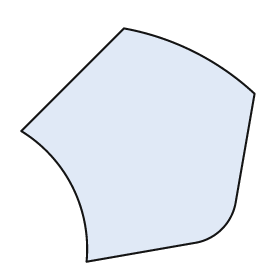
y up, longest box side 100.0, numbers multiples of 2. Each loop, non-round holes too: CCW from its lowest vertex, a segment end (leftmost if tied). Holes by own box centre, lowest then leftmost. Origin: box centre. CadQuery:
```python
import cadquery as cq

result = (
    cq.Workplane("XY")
    .moveTo(-22.0, -50.0)
    .lineTo(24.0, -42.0)
    .threePointArc((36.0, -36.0), (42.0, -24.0))
    .lineTo(50.0, 22.0)
    .threePointArc((24.0, 40.0), (-6.0, 50.0))
    .lineTo(-50.0, 6.0)
    .threePointArc((-28.0, -18.0), (-22.0, -50.0))
    .close()
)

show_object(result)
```